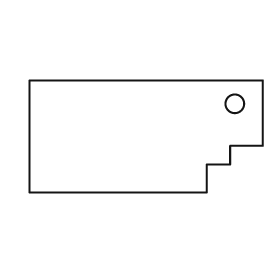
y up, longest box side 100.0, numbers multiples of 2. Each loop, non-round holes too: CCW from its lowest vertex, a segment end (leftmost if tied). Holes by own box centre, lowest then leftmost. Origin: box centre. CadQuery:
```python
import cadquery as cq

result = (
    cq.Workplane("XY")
    .moveTo(-50.0, -24.0)
    .lineTo(26.0, -24.0)
    .lineTo(26.0, -12.0)
    .lineTo(36.0, -12.0)
    .lineTo(36.0, -4.0)
    .lineTo(50.0, -4.0)
    .lineTo(50.0, 24.0)
    .lineTo(-50.0, 24.0)
    .close()
    .moveTo(38.0, 14.0)
    .circle(4.0)
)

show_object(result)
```